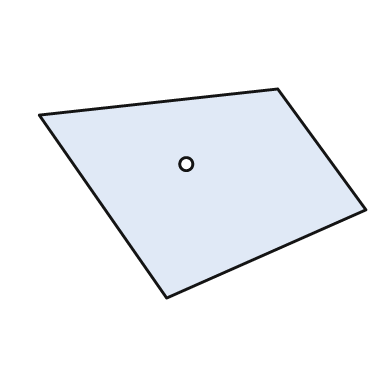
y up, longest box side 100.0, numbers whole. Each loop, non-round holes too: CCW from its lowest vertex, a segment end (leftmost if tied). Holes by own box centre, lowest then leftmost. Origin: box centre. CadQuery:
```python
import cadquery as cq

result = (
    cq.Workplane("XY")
    .moveTo(-11.0, -32.0)
    .lineTo(50.0, -5.0)
    .lineTo(23.0, 32.0)
    .lineTo(-50.0, 24.0)
    .close()
    .moveTo(-5.0, 9.0)
    .circle(2.0)
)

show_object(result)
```